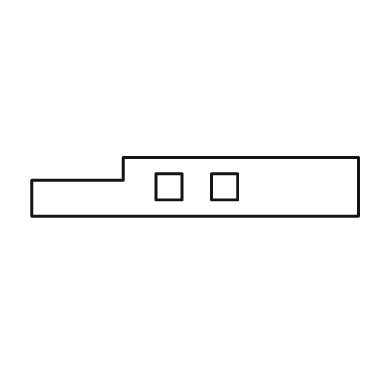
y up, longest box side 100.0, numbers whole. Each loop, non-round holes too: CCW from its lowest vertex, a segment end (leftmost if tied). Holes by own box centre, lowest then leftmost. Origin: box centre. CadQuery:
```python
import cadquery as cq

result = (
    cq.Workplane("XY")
    .moveTo(-50.0, -9.0)
    .lineTo(50.0, -9.0)
    .lineTo(50.0, 9.0)
    .lineTo(-22.0, 9.0)
    .lineTo(-22.0, 2.0)
    .lineTo(-50.0, 2.0)
    .close()
    .moveTo(-12.0, -4.0)
    .lineTo(-4.0, -4.0)
    .lineTo(-4.0, 4.0)
    .lineTo(-12.0, 4.0)
    .close()
    .moveTo(5.0, -4.0)
    .lineTo(13.0, -4.0)
    .lineTo(13.0, 4.0)
    .lineTo(5.0, 4.0)
    .close()
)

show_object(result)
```